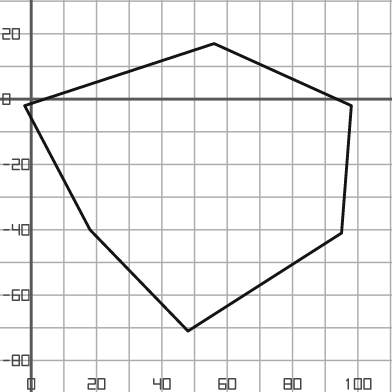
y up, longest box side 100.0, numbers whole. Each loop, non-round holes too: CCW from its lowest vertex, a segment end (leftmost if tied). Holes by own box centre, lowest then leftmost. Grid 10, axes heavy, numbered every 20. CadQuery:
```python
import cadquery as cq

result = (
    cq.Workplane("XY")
    .moveTo(48.0, -71.0)
    .lineTo(95.0, -41.0)
    .lineTo(98.0, -2.0)
    .lineTo(56.0, 17.0)
    .lineTo(-2.0, -2.0)
    .lineTo(18.0, -40.0)
    .close()
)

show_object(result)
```